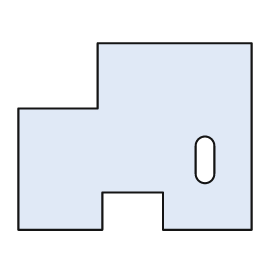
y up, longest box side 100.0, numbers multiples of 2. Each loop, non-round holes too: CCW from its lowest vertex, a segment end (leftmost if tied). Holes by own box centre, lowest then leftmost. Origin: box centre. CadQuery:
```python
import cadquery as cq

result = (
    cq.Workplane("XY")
    .moveTo(-50.0, -40.0)
    .lineTo(-14.0, -40.0)
    .lineTo(-14.0, -24.0)
    .lineTo(12.0, -24.0)
    .lineTo(12.0, -40.0)
    .lineTo(50.0, -40.0)
    .lineTo(50.0, 40.0)
    .lineTo(-16.0, 40.0)
    .lineTo(-16.0, 12.0)
    .lineTo(-50.0, 12.0)
    .close()
    .moveTo(26.0, -16.0)
    .threePointArc((30.0, -20.0), (34.0, -16.0))
    .lineTo(34.0, -4.0)
    .threePointArc((30.0, 0.0), (26.0, -4.0))
    .close()
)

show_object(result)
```